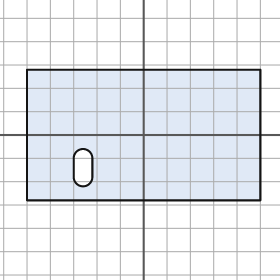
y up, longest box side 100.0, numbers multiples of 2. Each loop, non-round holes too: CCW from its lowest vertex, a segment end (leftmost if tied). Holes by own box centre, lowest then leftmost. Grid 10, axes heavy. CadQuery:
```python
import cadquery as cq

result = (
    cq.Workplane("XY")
    .moveTo(-50.0, -28.0)
    .lineTo(50.0, -28.0)
    .lineTo(50.0, 28.0)
    .lineTo(-50.0, 28.0)
    .close()
    .moveTo(-30.0, -18.0)
    .threePointArc((-26.0, -22.0), (-22.0, -18.0))
    .lineTo(-22.0, -10.0)
    .threePointArc((-26.0, -6.0), (-30.0, -10.0))
    .close()
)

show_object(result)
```